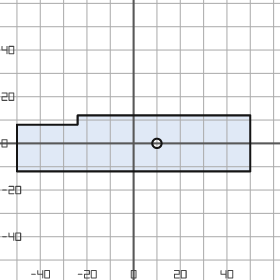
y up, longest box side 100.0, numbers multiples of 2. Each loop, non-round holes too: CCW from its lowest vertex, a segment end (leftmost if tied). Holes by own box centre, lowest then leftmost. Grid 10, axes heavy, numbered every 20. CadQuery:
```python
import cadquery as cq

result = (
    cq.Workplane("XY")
    .moveTo(-50.0, -12.0)
    .lineTo(50.0, -12.0)
    .lineTo(50.0, 12.0)
    .lineTo(-24.0, 12.0)
    .lineTo(-24.0, 8.0)
    .lineTo(-50.0, 8.0)
    .close()
    .moveTo(10.0, 0.0)
    .circle(2.0)
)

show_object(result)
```